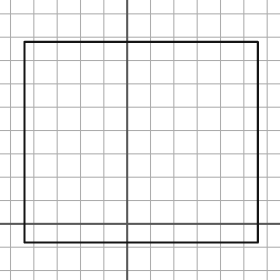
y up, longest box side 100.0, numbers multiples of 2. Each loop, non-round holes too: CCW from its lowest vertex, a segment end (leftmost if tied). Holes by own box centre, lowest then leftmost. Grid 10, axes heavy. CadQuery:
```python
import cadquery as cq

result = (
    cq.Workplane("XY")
    .moveTo(-44.0, -8.0)
    .lineTo(56.0, -8.0)
    .lineTo(56.0, 78.0)
    .lineTo(-44.0, 78.0)
    .close()
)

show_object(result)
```